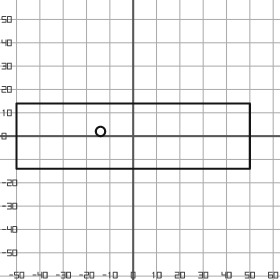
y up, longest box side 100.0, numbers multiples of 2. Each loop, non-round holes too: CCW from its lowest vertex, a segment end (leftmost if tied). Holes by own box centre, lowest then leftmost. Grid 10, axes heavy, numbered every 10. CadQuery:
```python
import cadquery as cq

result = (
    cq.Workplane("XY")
    .moveTo(-50.0, -14.0)
    .lineTo(50.0, -14.0)
    .lineTo(50.0, 14.0)
    .lineTo(-50.0, 14.0)
    .close()
    .moveTo(-14.0, 2.0)
    .circle(2.0)
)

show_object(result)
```